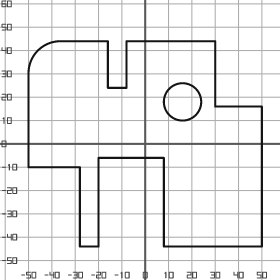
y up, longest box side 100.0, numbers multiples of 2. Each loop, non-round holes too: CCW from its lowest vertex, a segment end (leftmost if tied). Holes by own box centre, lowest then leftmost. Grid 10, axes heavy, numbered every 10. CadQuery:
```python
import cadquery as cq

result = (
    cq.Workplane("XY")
    .moveTo(-28.0, -44.0)
    .lineTo(-20.0, -44.0)
    .lineTo(-20.0, -6.0)
    .lineTo(8.0, -6.0)
    .lineTo(8.0, -44.0)
    .lineTo(50.0, -44.0)
    .lineTo(50.0, 16.0)
    .lineTo(30.0, 16.0)
    .lineTo(30.0, 44.0)
    .lineTo(-8.0, 44.0)
    .lineTo(-8.0, 24.0)
    .lineTo(-16.0, 24.0)
    .lineTo(-16.0, 44.0)
    .lineTo(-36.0, 44.0)
    .threePointArc((-46.0, 40.0), (-50.0, 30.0))
    .lineTo(-50.0, -10.0)
    .lineTo(-28.0, -10.0)
    .close()
    .moveTo(16.0, 18.0)
    .circle(8.0)
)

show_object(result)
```